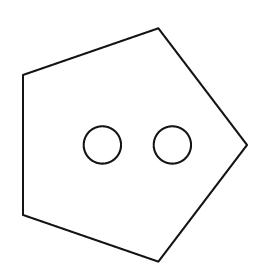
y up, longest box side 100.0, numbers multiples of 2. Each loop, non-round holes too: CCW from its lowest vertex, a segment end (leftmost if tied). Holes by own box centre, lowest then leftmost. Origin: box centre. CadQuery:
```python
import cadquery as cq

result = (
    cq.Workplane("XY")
    .moveTo(10.0, -50.0)
    .lineTo(48.0, 0.0)
    .lineTo(10.0, 50.0)
    .lineTo(-48.0, 30.0)
    .lineTo(-48.0, -30.0)
    .close()
    .moveTo(-14.0, 0.0)
    .circle(8.0)
    .moveTo(16.0, 0.0)
    .circle(8.0)
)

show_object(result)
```